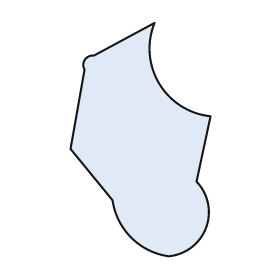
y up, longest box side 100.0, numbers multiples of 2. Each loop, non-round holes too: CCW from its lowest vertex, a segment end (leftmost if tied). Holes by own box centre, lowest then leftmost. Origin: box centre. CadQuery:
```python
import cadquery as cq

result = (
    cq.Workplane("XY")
    .moveTo(12.0, -50.0)
    .threePointArc((28.0, -38.0), (24.0, -18.0))
    .lineTo(30.0, 10.0)
    .threePointArc((8.0, 24.0), (6.0, 50.0))
    .lineTo(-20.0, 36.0)
    .threePointArc((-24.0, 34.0), (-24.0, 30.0))
    .lineTo(-30.0, -4.0)
    .lineTo(-12.0, -26.0)
    .threePointArc((-4.0, -42.0), (12.0, -50.0))
    .close()
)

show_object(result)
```